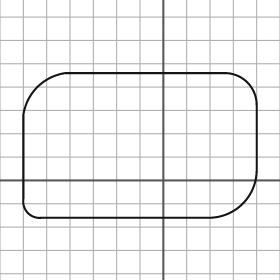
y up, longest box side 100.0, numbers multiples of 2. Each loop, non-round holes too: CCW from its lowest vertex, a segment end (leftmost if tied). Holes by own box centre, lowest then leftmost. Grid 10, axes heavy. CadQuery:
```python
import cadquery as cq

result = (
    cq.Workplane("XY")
    .moveTo(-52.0, -16.0)
    .lineTo(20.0, -16.0)
    .threePointArc((34.0, -10.0), (40.0, 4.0))
    .lineTo(40.0, 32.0)
    .threePointArc((36.0, 42.0), (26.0, 46.0))
    .lineTo(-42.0, 46.0)
    .threePointArc((-54.0, 40.0), (-60.0, 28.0))
    .lineTo(-60.0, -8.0)
    .threePointArc((-58.0, -14.0), (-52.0, -16.0))
    .close()
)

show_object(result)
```